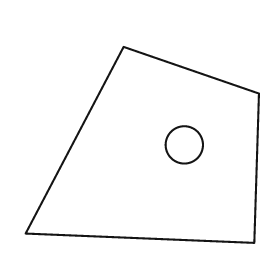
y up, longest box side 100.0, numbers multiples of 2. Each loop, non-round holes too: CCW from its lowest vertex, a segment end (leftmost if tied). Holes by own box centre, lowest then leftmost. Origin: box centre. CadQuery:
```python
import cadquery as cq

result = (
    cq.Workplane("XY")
    .moveTo(48.0, -42.0)
    .lineTo(50.0, 22.0)
    .lineTo(-8.0, 42.0)
    .lineTo(-50.0, -38.0)
    .close()
    .moveTo(18.0, 0.0)
    .circle(8.0)
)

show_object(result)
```